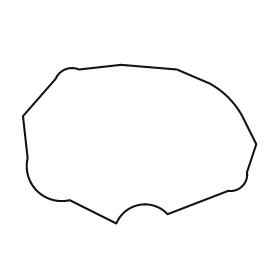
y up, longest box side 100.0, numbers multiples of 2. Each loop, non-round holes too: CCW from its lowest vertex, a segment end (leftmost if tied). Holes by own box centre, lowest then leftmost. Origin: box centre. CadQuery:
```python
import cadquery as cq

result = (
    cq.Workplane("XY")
    .moveTo(-10.0, -34.0)
    .threePointArc((0.0, -26.0), (12.0, -30.0))
    .lineTo(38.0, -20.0)
    .threePointArc((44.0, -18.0), (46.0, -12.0))
    .lineTo(50.0, 0.0)
    .lineTo(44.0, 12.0)
    .threePointArc((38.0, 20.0), (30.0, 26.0))
    .lineTo(16.0, 32.0)
    .lineTo(-8.0, 34.0)
    .lineTo(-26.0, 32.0)
    .threePointArc((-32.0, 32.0), (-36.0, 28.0))
    .lineTo(-50.0, 12.0)
    .lineTo(-48.0, -6.0)
    .threePointArc((-44.0, -20.0), (-30.0, -24.0))
    .close()
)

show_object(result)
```